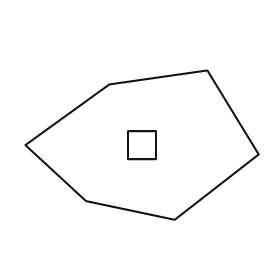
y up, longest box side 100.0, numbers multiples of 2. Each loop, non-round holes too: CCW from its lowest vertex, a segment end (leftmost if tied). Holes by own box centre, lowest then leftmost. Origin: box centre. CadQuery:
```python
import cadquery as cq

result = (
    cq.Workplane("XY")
    .moveTo(14.0, -32.0)
    .lineTo(50.0, -4.0)
    .lineTo(28.0, 32.0)
    .lineTo(-14.0, 26.0)
    .lineTo(-50.0, 0.0)
    .lineTo(-24.0, -24.0)
    .close()
    .moveTo(-6.0, -6.0)
    .lineTo(6.0, -6.0)
    .lineTo(6.0, 6.0)
    .lineTo(-6.0, 6.0)
    .close()
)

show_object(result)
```